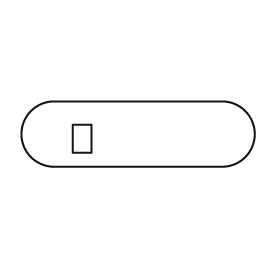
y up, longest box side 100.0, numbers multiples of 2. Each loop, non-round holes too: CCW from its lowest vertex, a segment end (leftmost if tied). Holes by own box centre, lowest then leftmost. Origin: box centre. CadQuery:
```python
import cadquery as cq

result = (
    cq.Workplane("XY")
    .moveTo(-36.0, -14.0)
    .lineTo(36.0, -14.0)
    .threePointArc((50.0, 0.0), (36.0, 14.0))
    .lineTo(-36.0, 14.0)
    .threePointArc((-50.0, 0.0), (-36.0, -14.0))
    .close()
    .moveTo(-28.0, -8.0)
    .lineTo(-20.0, -8.0)
    .lineTo(-20.0, 4.0)
    .lineTo(-28.0, 4.0)
    .close()
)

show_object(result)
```